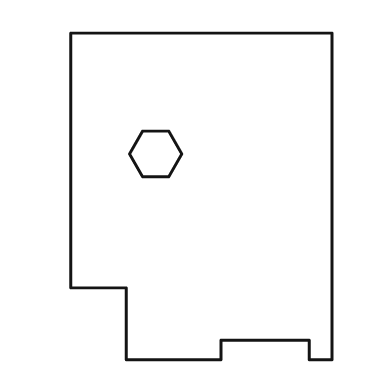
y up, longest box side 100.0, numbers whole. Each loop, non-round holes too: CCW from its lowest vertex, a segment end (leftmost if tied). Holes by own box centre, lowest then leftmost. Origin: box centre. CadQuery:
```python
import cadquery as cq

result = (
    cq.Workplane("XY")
    .moveTo(-23.0, -50.0)
    .lineTo(6.0, -50.0)
    .lineTo(6.0, -44.0)
    .lineTo(33.0, -44.0)
    .lineTo(33.0, -50.0)
    .lineTo(40.0, -50.0)
    .lineTo(40.0, 50.0)
    .lineTo(-40.0, 50.0)
    .lineTo(-40.0, -28.0)
    .lineTo(-23.0, -28.0)
    .close()
    .moveTo(-18.0, 6.0)
    .lineTo(-10.0, 6.0)
    .lineTo(-6.0, 13.0)
    .lineTo(-10.0, 20.0)
    .lineTo(-18.0, 20.0)
    .lineTo(-22.0, 13.0)
    .close()
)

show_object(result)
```